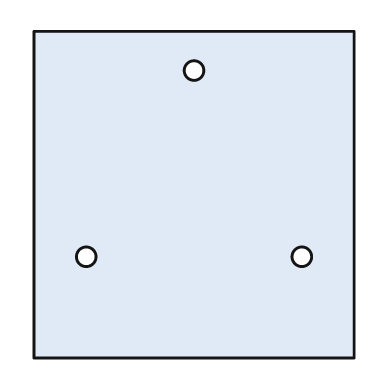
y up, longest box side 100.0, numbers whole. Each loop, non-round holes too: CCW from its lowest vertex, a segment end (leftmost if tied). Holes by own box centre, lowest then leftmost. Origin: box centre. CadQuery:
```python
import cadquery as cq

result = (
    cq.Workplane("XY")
    .moveTo(-49.0, -50.0)
    .lineTo(49.0, -50.0)
    .lineTo(49.0, 50.0)
    .lineTo(-49.0, 50.0)
    .close()
    .moveTo(-33.0, -19.0)
    .circle(3.0)
    .moveTo(33.0, -19.0)
    .circle(3.0)
    .moveTo(0.0, 38.0)
    .circle(3.0)
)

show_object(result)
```